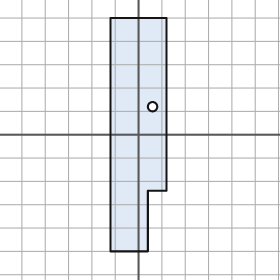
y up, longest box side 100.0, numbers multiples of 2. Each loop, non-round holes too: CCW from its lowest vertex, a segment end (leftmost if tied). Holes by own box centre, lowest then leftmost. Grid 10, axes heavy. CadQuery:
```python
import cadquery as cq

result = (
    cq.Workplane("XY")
    .moveTo(-12.0, -50.0)
    .lineTo(4.0, -50.0)
    .lineTo(4.0, -24.0)
    .lineTo(12.0, -24.0)
    .lineTo(12.0, 50.0)
    .lineTo(-12.0, 50.0)
    .close()
    .moveTo(6.0, 12.0)
    .circle(2.0)
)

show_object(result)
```